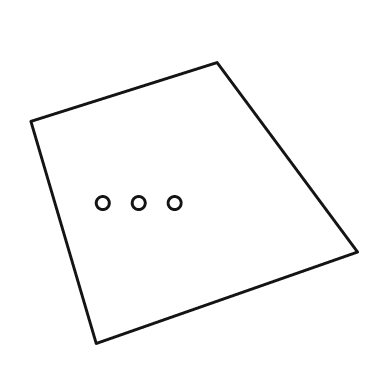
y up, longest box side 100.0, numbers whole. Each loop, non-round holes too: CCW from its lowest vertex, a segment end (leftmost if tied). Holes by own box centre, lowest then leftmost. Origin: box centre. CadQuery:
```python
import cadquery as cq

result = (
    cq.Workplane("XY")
    .moveTo(-30.0, -43.0)
    .lineTo(50.0, -15.0)
    .lineTo(7.0, 43.0)
    .lineTo(-50.0, 25.0)
    .close()
    .moveTo(-28.0, 0.0)
    .circle(2.0)
    .moveTo(-17.0, 0.0)
    .circle(2.0)
    .moveTo(-6.0, 0.0)
    .circle(2.0)
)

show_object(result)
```